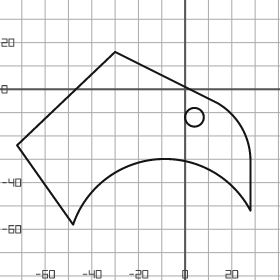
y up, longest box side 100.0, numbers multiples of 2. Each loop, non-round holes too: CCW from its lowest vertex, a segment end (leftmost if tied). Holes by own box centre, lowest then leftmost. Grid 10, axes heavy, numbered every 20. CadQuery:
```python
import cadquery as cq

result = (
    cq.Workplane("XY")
    .moveTo(-48.0, -58.0)
    .threePointArc((-12.0, -30.0), (28.0, -52.0))
    .lineTo(28.0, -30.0)
    .threePointArc((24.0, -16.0), (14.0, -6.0))
    .lineTo(-30.0, 16.0)
    .lineTo(-72.0, -24.0)
    .close()
    .moveTo(4.0, -12.0)
    .circle(4.0)
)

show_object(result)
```